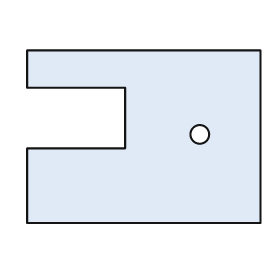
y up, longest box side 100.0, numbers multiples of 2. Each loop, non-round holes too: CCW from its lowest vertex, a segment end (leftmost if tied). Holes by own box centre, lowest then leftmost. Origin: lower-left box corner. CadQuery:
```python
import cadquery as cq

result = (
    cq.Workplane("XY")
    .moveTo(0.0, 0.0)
    .lineTo(100.0, 0.0)
    .lineTo(100.0, 74.0)
    .lineTo(0.0, 74.0)
    .lineTo(0.0, 58.0)
    .lineTo(42.0, 58.0)
    .lineTo(42.0, 32.0)
    .lineTo(0.0, 32.0)
    .close()
    .moveTo(74.0, 38.0)
    .circle(4.0)
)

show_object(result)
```